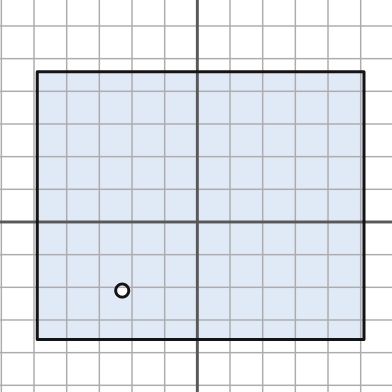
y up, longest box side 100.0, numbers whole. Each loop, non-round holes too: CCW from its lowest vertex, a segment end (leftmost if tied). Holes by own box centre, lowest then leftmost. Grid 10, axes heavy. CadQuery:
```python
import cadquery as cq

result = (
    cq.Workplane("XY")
    .moveTo(-49.0, -36.0)
    .lineTo(51.0, -36.0)
    .lineTo(51.0, 46.0)
    .lineTo(-49.0, 46.0)
    .close()
    .moveTo(-23.0, -21.0)
    .circle(2.0)
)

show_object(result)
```